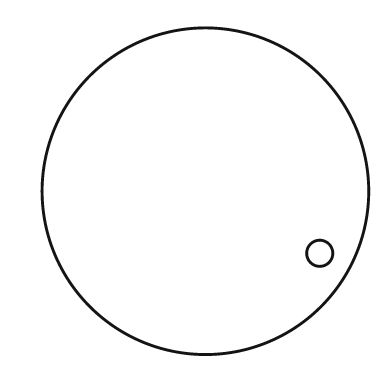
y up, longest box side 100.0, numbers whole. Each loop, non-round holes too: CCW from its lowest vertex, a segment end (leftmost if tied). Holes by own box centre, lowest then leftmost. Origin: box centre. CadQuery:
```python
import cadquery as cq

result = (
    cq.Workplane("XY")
    .moveTo(0.0, 0.0)
    .circle(50.0)
    .moveTo(35.0, -19.0)
    .circle(4.0)
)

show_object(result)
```